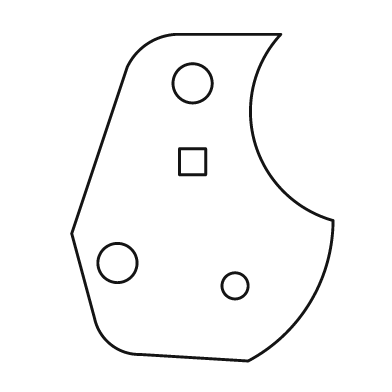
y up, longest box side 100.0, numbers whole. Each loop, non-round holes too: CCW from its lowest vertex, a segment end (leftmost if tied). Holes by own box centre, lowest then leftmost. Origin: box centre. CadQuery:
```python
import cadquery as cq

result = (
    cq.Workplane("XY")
    .moveTo(14.0, -50.0)
    .threePointArc((33.0, -32.0), (40.0, -7.0))
    .threePointArc((16.0, 17.0), (24.0, 50.0))
    .lineTo(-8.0, 50.0)
    .threePointArc((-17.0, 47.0), (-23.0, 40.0))
    .lineTo(-40.0, -11.0)
    .lineTo(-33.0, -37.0)
    .threePointArc((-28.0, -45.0), (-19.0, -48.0))
    .close()
    .moveTo(10.0, -27.0)
    .circle(4.0)
    .moveTo(-26.0, -20.0)
    .circle(6.0)
    .moveTo(-7.0, 7.0)
    .lineTo(1.0, 7.0)
    .lineTo(1.0, 15.0)
    .lineTo(-7.0, 15.0)
    .close()
    .moveTo(-3.0, 35.0)
    .circle(6.0)
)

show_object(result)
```